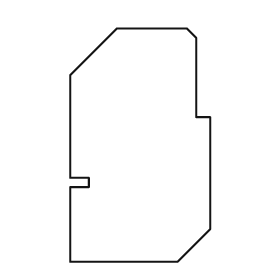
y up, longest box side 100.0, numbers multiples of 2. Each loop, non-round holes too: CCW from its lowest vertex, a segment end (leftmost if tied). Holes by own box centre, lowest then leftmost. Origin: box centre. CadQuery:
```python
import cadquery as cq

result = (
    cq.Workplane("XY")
    .moveTo(-30.0, -50.0)
    .lineTo(16.0, -50.0)
    .lineTo(30.0, -36.0)
    .lineTo(30.0, 12.0)
    .lineTo(24.0, 12.0)
    .lineTo(24.0, 46.0)
    .lineTo(20.0, 50.0)
    .lineTo(-10.0, 50.0)
    .lineTo(-30.0, 30.0)
    .lineTo(-30.0, -14.0)
    .lineTo(-22.0, -14.0)
    .lineTo(-22.0, -18.0)
    .lineTo(-30.0, -18.0)
    .close()
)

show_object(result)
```